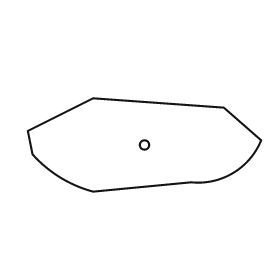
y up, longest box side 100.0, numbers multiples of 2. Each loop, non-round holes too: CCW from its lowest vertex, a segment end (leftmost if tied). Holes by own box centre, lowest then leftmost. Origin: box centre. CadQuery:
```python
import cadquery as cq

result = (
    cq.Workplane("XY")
    .moveTo(-22.0, -20.0)
    .lineTo(20.0, -16.0)
    .threePointArc((38.0, -12.0), (50.0, 2.0))
    .lineTo(34.0, 16.0)
    .lineTo(-22.0, 20.0)
    .lineTo(-50.0, 6.0)
    .lineTo(-48.0, -4.0)
    .threePointArc((-36.0, -14.0), (-22.0, -20.0))
    .close()
    .moveTo(0.0, 0.0)
    .circle(2.0)
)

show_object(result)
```